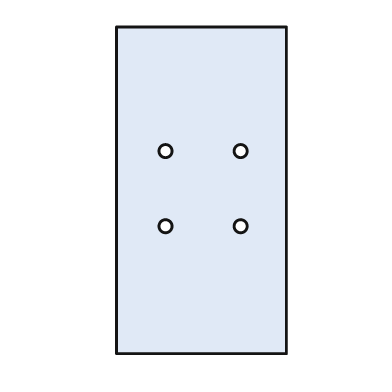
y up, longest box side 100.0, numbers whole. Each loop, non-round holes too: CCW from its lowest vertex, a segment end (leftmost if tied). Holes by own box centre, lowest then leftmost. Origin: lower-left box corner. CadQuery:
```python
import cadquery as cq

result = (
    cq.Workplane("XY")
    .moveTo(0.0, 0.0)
    .lineTo(52.0, 0.0)
    .lineTo(52.0, 100.0)
    .lineTo(0.0, 100.0)
    .close()
    .moveTo(15.0, 39.0)
    .circle(2.0)
    .moveTo(38.0, 39.0)
    .circle(2.0)
    .moveTo(15.0, 62.0)
    .circle(2.0)
    .moveTo(38.0, 62.0)
    .circle(2.0)
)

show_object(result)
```